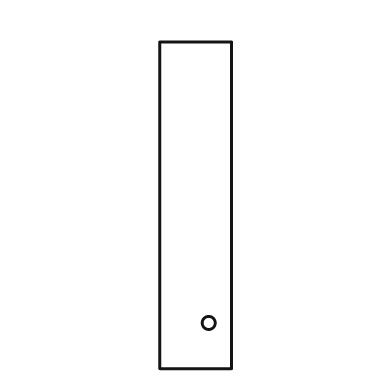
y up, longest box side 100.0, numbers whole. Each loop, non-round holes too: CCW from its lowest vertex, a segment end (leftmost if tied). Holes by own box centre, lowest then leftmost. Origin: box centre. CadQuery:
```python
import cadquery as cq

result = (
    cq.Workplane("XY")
    .moveTo(-11.0, -50.0)
    .lineTo(11.0, -50.0)
    .lineTo(11.0, 50.0)
    .lineTo(-11.0, 50.0)
    .close()
    .moveTo(4.0, -36.0)
    .circle(2.0)
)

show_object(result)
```